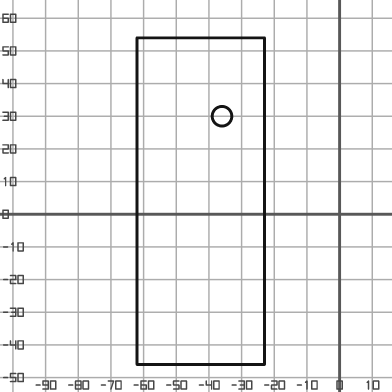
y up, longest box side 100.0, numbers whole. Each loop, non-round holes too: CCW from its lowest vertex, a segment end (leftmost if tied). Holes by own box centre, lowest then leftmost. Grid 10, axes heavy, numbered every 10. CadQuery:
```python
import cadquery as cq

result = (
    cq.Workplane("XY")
    .moveTo(-62.0, -46.0)
    .lineTo(-23.0, -46.0)
    .lineTo(-23.0, 54.0)
    .lineTo(-62.0, 54.0)
    .close()
    .moveTo(-36.0, 30.0)
    .circle(3.0)
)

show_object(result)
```